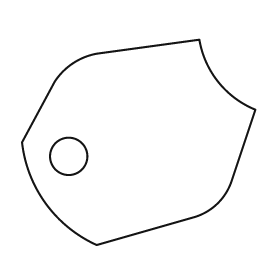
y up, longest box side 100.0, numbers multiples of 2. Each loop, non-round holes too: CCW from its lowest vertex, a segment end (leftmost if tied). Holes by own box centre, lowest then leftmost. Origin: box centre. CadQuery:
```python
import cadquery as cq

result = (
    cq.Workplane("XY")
    .moveTo(-18.0, -44.0)
    .lineTo(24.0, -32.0)
    .threePointArc((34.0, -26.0), (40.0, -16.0))
    .lineTo(50.0, 14.0)
    .threePointArc((34.0, 26.0), (26.0, 44.0))
    .lineTo(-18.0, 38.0)
    .threePointArc((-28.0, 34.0), (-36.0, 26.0))
    .lineTo(-50.0, 0.0)
    .threePointArc((-40.0, -26.0), (-18.0, -44.0))
    .close()
    .moveTo(-30.0, -6.0)
    .circle(8.0)
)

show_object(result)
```